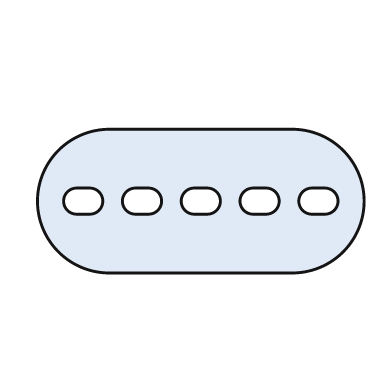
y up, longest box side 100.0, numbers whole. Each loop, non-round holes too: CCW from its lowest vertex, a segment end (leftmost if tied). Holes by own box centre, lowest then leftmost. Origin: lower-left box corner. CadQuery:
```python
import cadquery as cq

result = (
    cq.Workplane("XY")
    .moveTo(22.0, 0.0)
    .lineTo(78.0, 0.0)
    .threePointArc((100.0, 22.0), (78.0, 44.0))
    .lineTo(22.0, 44.0)
    .threePointArc((0.0, 22.0), (22.0, 0.0))
    .close()
    .moveTo(12.0, 18.0)
    .lineTo(16.0, 18.0)
    .threePointArc((20.0, 22.0), (16.0, 26.0))
    .lineTo(12.0, 26.0)
    .threePointArc((8.0, 22.0), (12.0, 18.0))
    .close()
    .moveTo(30.0, 18.0)
    .lineTo(34.0, 18.0)
    .threePointArc((38.0, 22.0), (34.0, 26.0))
    .lineTo(30.0, 26.0)
    .threePointArc((26.0, 22.0), (30.0, 18.0))
    .close()
    .moveTo(48.0, 18.0)
    .lineTo(52.0, 18.0)
    .threePointArc((56.0, 22.0), (52.0, 26.0))
    .lineTo(48.0, 26.0)
    .threePointArc((44.0, 22.0), (48.0, 18.0))
    .close()
    .moveTo(66.0, 18.0)
    .lineTo(70.0, 18.0)
    .threePointArc((74.0, 22.0), (70.0, 26.0))
    .lineTo(66.0, 26.0)
    .threePointArc((62.0, 22.0), (66.0, 18.0))
    .close()
    .moveTo(84.0, 18.0)
    .lineTo(88.0, 18.0)
    .threePointArc((92.0, 22.0), (88.0, 26.0))
    .lineTo(84.0, 26.0)
    .threePointArc((80.0, 22.0), (84.0, 18.0))
    .close()
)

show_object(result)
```